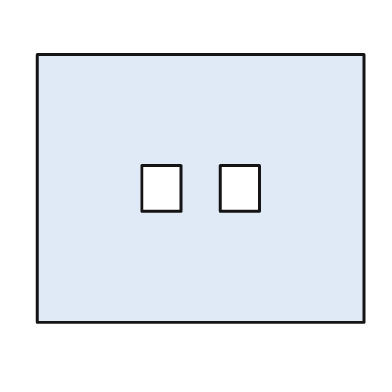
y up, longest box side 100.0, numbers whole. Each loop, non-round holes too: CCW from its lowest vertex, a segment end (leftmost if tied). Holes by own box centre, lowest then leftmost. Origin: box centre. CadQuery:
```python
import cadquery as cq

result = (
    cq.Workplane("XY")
    .moveTo(-50.0, -41.0)
    .lineTo(50.0, -41.0)
    .lineTo(50.0, 41.0)
    .lineTo(-50.0, 41.0)
    .close()
    .moveTo(-18.0, -7.0)
    .lineTo(-6.0, -7.0)
    .lineTo(-6.0, 7.0)
    .lineTo(-18.0, 7.0)
    .close()
    .moveTo(6.0, -7.0)
    .lineTo(18.0, -7.0)
    .lineTo(18.0, 7.0)
    .lineTo(6.0, 7.0)
    .close()
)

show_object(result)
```